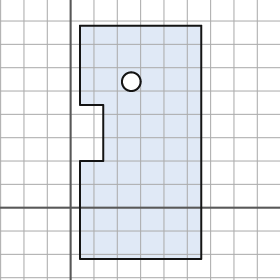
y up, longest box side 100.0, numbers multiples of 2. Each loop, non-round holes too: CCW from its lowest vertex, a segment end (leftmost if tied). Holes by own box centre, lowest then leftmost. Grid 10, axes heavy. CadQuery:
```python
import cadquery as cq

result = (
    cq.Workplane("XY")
    .moveTo(4.0, -22.0)
    .lineTo(56.0, -22.0)
    .lineTo(56.0, 78.0)
    .lineTo(4.0, 78.0)
    .lineTo(4.0, 44.0)
    .lineTo(14.0, 44.0)
    .lineTo(14.0, 20.0)
    .lineTo(4.0, 20.0)
    .close()
    .moveTo(26.0, 54.0)
    .circle(4.0)
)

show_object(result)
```